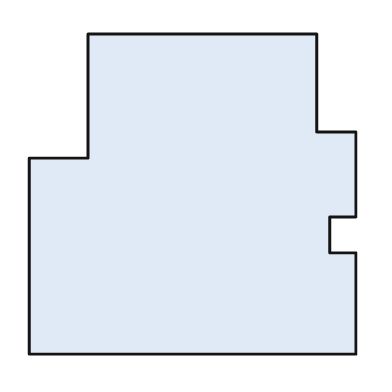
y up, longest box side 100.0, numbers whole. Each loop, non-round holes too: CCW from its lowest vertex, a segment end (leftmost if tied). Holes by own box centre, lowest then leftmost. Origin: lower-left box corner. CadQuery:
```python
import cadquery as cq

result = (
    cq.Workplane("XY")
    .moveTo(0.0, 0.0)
    .lineTo(100.0, 0.0)
    .lineTo(100.0, 31.0)
    .lineTo(92.0, 31.0)
    .lineTo(92.0, 42.0)
    .lineTo(100.0, 42.0)
    .lineTo(100.0, 68.0)
    .lineTo(88.0, 68.0)
    .lineTo(88.0, 98.0)
    .lineTo(18.0, 98.0)
    .lineTo(18.0, 60.0)
    .lineTo(0.0, 60.0)
    .close()
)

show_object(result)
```